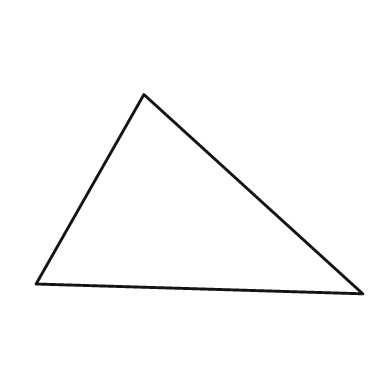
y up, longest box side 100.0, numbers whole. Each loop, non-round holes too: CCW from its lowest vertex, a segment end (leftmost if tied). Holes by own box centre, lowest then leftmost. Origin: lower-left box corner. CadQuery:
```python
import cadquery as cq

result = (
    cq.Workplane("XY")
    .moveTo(100.0, 0.0)
    .lineTo(33.0, 61.0)
    .lineTo(0.0, 3.0)
    .close()
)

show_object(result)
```